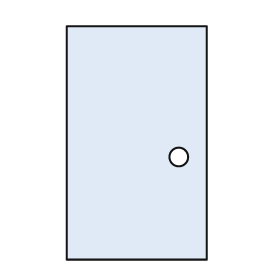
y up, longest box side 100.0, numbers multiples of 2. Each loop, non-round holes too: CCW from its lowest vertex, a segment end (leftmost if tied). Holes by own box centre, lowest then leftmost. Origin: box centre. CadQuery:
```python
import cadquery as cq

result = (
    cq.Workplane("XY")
    .moveTo(-30.0, -50.0)
    .lineTo(30.0, -50.0)
    .lineTo(30.0, 50.0)
    .lineTo(-30.0, 50.0)
    .close()
    .moveTo(18.0, -6.0)
    .circle(4.0)
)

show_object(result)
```